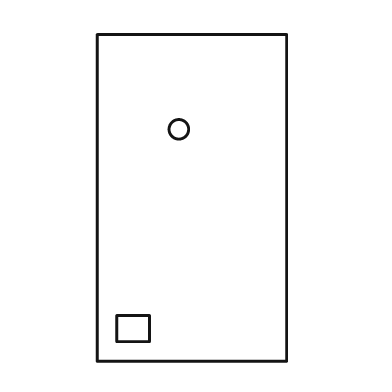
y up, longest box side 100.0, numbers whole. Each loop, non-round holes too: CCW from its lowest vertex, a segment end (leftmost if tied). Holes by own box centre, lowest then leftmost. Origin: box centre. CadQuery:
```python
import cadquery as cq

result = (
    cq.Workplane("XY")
    .moveTo(-29.0, -50.0)
    .lineTo(29.0, -50.0)
    .lineTo(29.0, 50.0)
    .lineTo(-29.0, 50.0)
    .close()
    .moveTo(-23.0, -44.0)
    .lineTo(-13.0, -44.0)
    .lineTo(-13.0, -36.0)
    .lineTo(-23.0, -36.0)
    .close()
    .moveTo(-4.0, 21.0)
    .circle(3.0)
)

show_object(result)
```